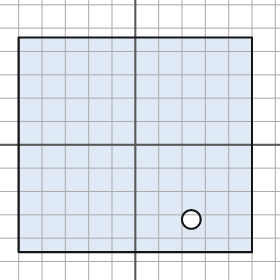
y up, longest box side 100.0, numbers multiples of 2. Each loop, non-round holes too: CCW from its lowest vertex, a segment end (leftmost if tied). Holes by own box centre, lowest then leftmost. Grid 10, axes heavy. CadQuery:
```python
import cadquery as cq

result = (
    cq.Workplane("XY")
    .moveTo(-50.0, -46.0)
    .lineTo(50.0, -46.0)
    .lineTo(50.0, 46.0)
    .lineTo(-50.0, 46.0)
    .close()
    .moveTo(24.0, -32.0)
    .circle(4.0)
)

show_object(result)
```